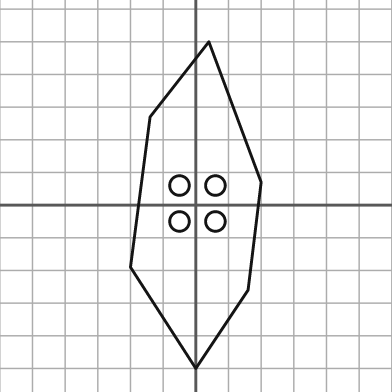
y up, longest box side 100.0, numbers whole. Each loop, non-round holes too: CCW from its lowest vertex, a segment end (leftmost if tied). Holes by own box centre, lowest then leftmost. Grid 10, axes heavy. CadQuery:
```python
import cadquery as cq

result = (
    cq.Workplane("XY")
    .moveTo(0.0, -50.0)
    .lineTo(16.0, -26.0)
    .lineTo(20.0, 7.0)
    .lineTo(4.0, 50.0)
    .lineTo(-14.0, 27.0)
    .lineTo(-20.0, -19.0)
    .close()
    .moveTo(-5.0, -5.0)
    .circle(3.0)
    .moveTo(6.0, -5.0)
    .circle(3.0)
    .moveTo(-5.0, 6.0)
    .circle(3.0)
    .moveTo(6.0, 6.0)
    .circle(3.0)
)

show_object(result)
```